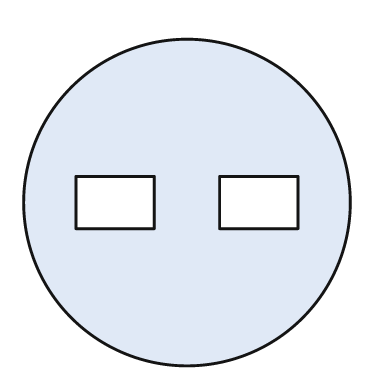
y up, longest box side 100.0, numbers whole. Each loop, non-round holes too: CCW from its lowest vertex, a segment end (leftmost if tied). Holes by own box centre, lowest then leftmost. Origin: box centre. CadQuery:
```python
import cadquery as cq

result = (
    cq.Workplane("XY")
    .moveTo(0.0, 0.0)
    .circle(50.0)
    .moveTo(-34.0, -8.0)
    .lineTo(-10.0, -8.0)
    .lineTo(-10.0, 8.0)
    .lineTo(-34.0, 8.0)
    .close()
    .moveTo(10.0, -8.0)
    .lineTo(34.0, -8.0)
    .lineTo(34.0, 8.0)
    .lineTo(10.0, 8.0)
    .close()
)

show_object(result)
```